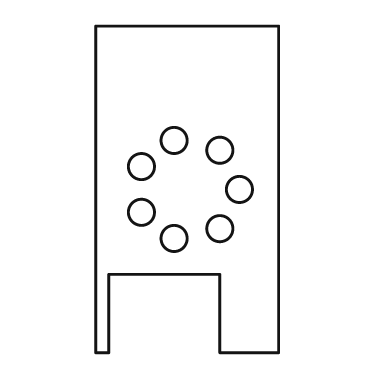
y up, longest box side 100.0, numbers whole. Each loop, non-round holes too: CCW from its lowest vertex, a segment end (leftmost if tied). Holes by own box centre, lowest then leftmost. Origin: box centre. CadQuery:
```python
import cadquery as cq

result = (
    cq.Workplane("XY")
    .moveTo(-28.0, -50.0)
    .lineTo(-24.0, -50.0)
    .lineTo(-24.0, -26.0)
    .lineTo(10.0, -26.0)
    .lineTo(10.0, -50.0)
    .lineTo(28.0, -50.0)
    .lineTo(28.0, 50.0)
    .lineTo(-28.0, 50.0)
    .close()
    .moveTo(-4.0, -15.0)
    .circle(4.0)
    .moveTo(10.0, -12.0)
    .circle(4.0)
    .moveTo(-14.0, -7.0)
    .circle(4.0)
    .moveTo(16.0, 0.0)
    .circle(4.0)
    .moveTo(-14.0, 7.0)
    .circle(4.0)
    .moveTo(10.0, 12.0)
    .circle(4.0)
    .moveTo(-4.0, 15.0)
    .circle(4.0)
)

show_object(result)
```